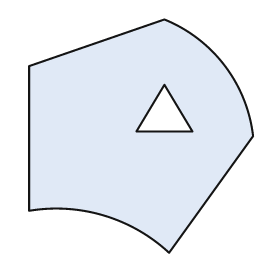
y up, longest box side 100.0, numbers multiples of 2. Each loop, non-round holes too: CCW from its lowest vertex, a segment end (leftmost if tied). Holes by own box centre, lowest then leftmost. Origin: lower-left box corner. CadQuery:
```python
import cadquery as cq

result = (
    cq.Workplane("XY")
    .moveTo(60.0, 0.0)
    .lineTo(96.0, 50.0)
    .threePointArc((84.0, 80.0), (58.0, 100.0))
    .lineTo(0.0, 80.0)
    .lineTo(0.0, 18.0)
    .threePointArc((32.0, 16.0), (60.0, 0.0))
    .close()
    .moveTo(46.0, 52.0)
    .lineTo(70.0, 52.0)
    .lineTo(58.0, 72.0)
    .close()
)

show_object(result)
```